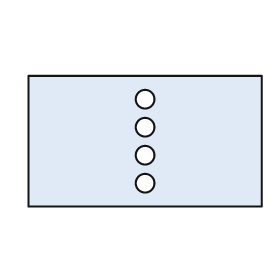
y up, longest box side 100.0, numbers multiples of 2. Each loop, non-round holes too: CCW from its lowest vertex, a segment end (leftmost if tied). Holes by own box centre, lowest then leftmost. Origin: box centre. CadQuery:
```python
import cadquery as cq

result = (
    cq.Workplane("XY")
    .moveTo(-50.0, -28.0)
    .lineTo(50.0, -28.0)
    .lineTo(50.0, 28.0)
    .lineTo(-50.0, 28.0)
    .close()
    .moveTo(0.0, -18.0)
    .circle(4.0)
    .moveTo(0.0, -6.0)
    .circle(4.0)
    .moveTo(0.0, 6.0)
    .circle(4.0)
    .moveTo(0.0, 18.0)
    .circle(4.0)
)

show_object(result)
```